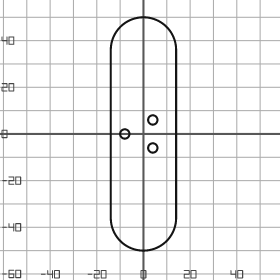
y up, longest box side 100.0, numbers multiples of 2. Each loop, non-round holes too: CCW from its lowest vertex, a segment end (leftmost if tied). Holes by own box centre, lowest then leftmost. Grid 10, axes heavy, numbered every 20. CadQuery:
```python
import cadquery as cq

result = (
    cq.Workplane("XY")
    .moveTo(-14.0, -36.0)
    .threePointArc((0.0, -50.0), (14.0, -36.0))
    .lineTo(14.0, 36.0)
    .threePointArc((0.0, 50.0), (-14.0, 36.0))
    .close()
    .moveTo(4.0, -6.0)
    .circle(2.0)
    .moveTo(-8.0, 0.0)
    .circle(2.0)
    .moveTo(4.0, 6.0)
    .circle(2.0)
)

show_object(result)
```